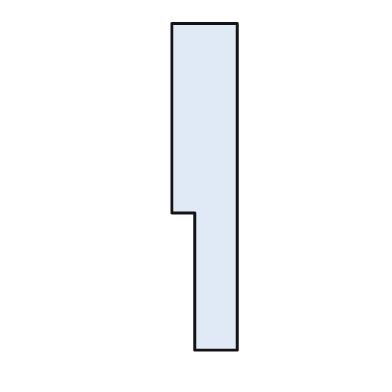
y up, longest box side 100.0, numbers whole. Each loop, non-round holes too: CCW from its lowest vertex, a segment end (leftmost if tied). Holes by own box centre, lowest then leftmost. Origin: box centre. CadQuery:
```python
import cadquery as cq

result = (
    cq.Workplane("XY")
    .moveTo(-3.0, -50.0)
    .lineTo(10.0, -50.0)
    .lineTo(10.0, 50.0)
    .lineTo(-10.0, 50.0)
    .lineTo(-10.0, -8.0)
    .lineTo(-3.0, -8.0)
    .close()
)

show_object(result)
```